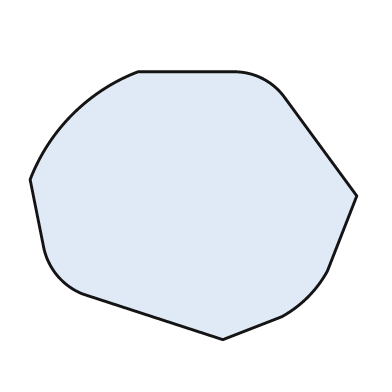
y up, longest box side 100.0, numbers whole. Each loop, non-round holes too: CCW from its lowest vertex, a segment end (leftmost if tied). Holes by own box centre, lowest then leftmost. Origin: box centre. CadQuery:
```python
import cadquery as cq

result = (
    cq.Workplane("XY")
    .moveTo(9.0, -41.0)
    .lineTo(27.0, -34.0)
    .threePointArc((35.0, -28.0), (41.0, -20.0))
    .lineTo(50.0, 3.0)
    .lineTo(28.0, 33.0)
    .threePointArc((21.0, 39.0), (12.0, 41.0))
    .lineTo(-17.0, 41.0)
    .threePointArc((-37.0, 28.0), (-50.0, 8.0))
    .lineTo(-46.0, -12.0)
    .threePointArc((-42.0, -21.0), (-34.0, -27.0))
    .close()
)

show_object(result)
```